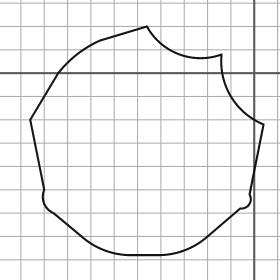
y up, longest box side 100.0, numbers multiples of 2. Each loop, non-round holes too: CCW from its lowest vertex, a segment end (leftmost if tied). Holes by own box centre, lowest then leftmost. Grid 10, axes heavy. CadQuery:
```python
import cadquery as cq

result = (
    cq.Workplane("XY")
    .moveTo(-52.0, -78.0)
    .lineTo(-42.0, -78.0)
    .threePointArc((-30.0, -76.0), (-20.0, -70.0))
    .lineTo(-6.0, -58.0)
    .threePointArc((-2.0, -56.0), (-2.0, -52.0))
    .lineTo(4.0, -22.0)
    .threePointArc((-10.0, -10.0), (-14.0, 8.0))
    .threePointArc((-32.0, 8.0), (-46.0, 20.0))
    .lineTo(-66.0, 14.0)
    .threePointArc((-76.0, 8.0), (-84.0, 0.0))
    .lineTo(-96.0, -20.0)
    .lineTo(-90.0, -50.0)
    .threePointArc((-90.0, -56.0), (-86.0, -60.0))
    .lineTo(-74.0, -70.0)
    .threePointArc((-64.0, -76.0), (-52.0, -78.0))
    .close()
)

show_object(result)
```